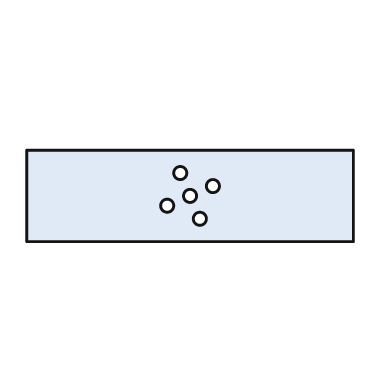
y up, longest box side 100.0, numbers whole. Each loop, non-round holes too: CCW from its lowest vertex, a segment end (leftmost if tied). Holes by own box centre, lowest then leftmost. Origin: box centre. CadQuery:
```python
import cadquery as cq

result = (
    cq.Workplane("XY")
    .moveTo(-50.0, -14.0)
    .lineTo(50.0, -14.0)
    .lineTo(50.0, 14.0)
    .lineTo(-50.0, 14.0)
    .close()
    .moveTo(3.0, -7.0)
    .circle(2.0)
    .moveTo(-7.0, -3.0)
    .circle(2.0)
    .moveTo(0.0, 0.0)
    .circle(2.0)
    .moveTo(7.0, 3.0)
    .circle(2.0)
    .moveTo(-3.0, 7.0)
    .circle(2.0)
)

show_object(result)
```